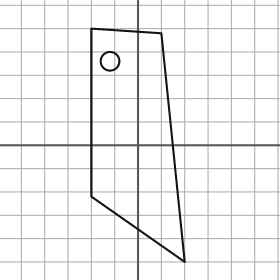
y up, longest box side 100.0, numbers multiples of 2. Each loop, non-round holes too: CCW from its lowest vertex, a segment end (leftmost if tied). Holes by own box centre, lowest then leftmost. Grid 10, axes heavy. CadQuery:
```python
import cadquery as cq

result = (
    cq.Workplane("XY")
    .moveTo(20.0, -50.0)
    .lineTo(10.0, 48.0)
    .lineTo(-20.0, 50.0)
    .lineTo(-20.0, -22.0)
    .close()
    .moveTo(-12.0, 36.0)
    .circle(4.0)
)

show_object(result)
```